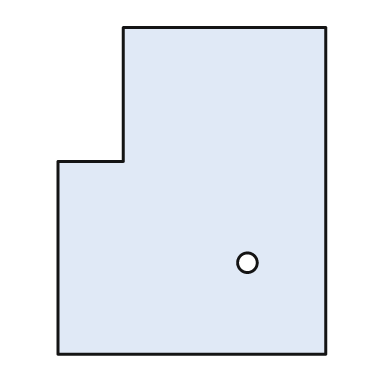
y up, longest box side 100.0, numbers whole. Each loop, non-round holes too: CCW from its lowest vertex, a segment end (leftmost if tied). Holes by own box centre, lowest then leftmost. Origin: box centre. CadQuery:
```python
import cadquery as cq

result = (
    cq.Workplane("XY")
    .moveTo(-41.0, -50.0)
    .lineTo(41.0, -50.0)
    .lineTo(41.0, 50.0)
    .lineTo(-21.0, 50.0)
    .lineTo(-21.0, 9.0)
    .lineTo(-41.0, 9.0)
    .close()
    .moveTo(17.0, -22.0)
    .circle(3.0)
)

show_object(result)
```